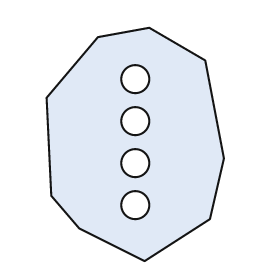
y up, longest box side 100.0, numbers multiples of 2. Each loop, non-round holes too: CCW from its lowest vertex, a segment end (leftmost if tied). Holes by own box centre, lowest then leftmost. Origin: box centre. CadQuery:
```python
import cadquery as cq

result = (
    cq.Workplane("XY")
    .moveTo(4.0, -50.0)
    .lineTo(32.0, -32.0)
    .lineTo(38.0, -6.0)
    .lineTo(30.0, 36.0)
    .lineTo(6.0, 50.0)
    .lineTo(-16.0, 46.0)
    .lineTo(-38.0, 20.0)
    .lineTo(-36.0, -22.0)
    .lineTo(-24.0, -36.0)
    .close()
    .moveTo(0.0, -26.0)
    .circle(6.0)
    .moveTo(0.0, -8.0)
    .circle(6.0)
    .moveTo(0.0, 10.0)
    .circle(6.0)
    .moveTo(0.0, 28.0)
    .circle(6.0)
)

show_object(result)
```